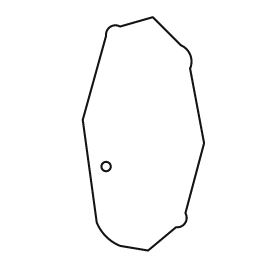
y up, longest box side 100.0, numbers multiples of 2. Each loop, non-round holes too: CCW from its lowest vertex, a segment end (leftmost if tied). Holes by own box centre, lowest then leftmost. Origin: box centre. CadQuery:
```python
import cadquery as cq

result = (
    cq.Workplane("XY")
    .moveTo(2.0, -50.0)
    .lineTo(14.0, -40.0)
    .threePointArc((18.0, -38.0), (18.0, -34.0))
    .lineTo(26.0, -4.0)
    .lineTo(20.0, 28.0)
    .threePointArc((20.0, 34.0), (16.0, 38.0))
    .lineTo(4.0, 50.0)
    .lineTo(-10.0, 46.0)
    .threePointArc((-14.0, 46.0), (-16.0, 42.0))
    .lineTo(-26.0, 6.0)
    .lineTo(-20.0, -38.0)
    .threePointArc((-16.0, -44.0), (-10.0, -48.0))
    .close()
    .moveTo(-16.0, -14.0)
    .circle(2.0)
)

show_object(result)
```